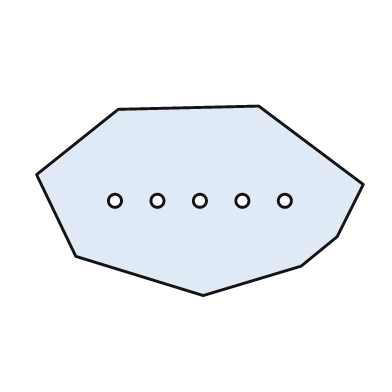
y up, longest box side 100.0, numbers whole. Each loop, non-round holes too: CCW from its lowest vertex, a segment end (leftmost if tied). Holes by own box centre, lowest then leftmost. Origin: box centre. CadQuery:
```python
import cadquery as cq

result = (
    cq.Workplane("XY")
    .moveTo(1.0, -29.0)
    .lineTo(31.0, -20.0)
    .lineTo(42.0, -11.0)
    .lineTo(50.0, 5.0)
    .lineTo(18.0, 29.0)
    .lineTo(-25.0, 28.0)
    .lineTo(-50.0, 8.0)
    .lineTo(-38.0, -17.0)
    .close()
    .moveTo(-26.0, 0.0)
    .circle(2.0)
    .moveTo(-13.0, 0.0)
    .circle(2.0)
    .moveTo(0.0, 0.0)
    .circle(2.0)
    .moveTo(13.0, 0.0)
    .circle(2.0)
    .moveTo(26.0, 0.0)
    .circle(2.0)
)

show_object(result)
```